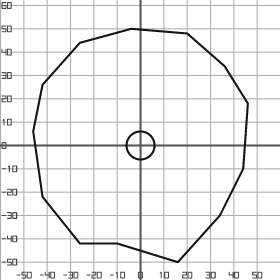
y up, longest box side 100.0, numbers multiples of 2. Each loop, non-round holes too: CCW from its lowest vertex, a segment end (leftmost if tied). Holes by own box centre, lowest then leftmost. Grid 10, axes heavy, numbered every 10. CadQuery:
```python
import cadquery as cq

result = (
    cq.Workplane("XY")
    .moveTo(16.0, -50.0)
    .lineTo(34.0, -30.0)
    .lineTo(44.0, -10.0)
    .lineTo(46.0, 18.0)
    .lineTo(36.0, 34.0)
    .lineTo(20.0, 48.0)
    .lineTo(-4.0, 50.0)
    .lineTo(-26.0, 44.0)
    .lineTo(-42.0, 26.0)
    .lineTo(-46.0, 6.0)
    .lineTo(-42.0, -22.0)
    .lineTo(-26.0, -42.0)
    .lineTo(-10.0, -42.0)
    .close()
    .moveTo(0.0, 0.0)
    .circle(6.0)
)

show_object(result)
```